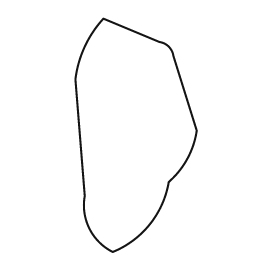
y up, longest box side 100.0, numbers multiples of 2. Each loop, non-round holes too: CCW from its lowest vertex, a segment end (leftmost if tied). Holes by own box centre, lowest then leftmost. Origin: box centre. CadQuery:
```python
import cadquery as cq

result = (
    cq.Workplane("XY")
    .moveTo(-10.0, -50.0)
    .threePointArc((6.0, -38.0), (14.0, -20.0))
    .threePointArc((22.0, -10.0), (26.0, 2.0))
    .lineTo(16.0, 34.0)
    .threePointArc((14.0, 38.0), (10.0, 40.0))
    .lineTo(-14.0, 50.0)
    .threePointArc((-22.0, 38.0), (-26.0, 24.0))
    .lineTo(-22.0, -26.0)
    .threePointArc((-20.0, -40.0), (-10.0, -50.0))
    .close()
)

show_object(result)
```